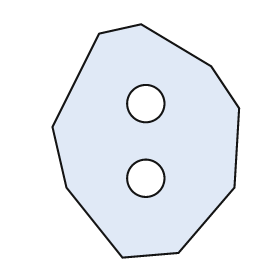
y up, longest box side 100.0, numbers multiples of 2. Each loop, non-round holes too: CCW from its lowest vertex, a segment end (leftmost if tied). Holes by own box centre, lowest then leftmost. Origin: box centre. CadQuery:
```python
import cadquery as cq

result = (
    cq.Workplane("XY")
    .moveTo(-10.0, -50.0)
    .lineTo(14.0, -48.0)
    .lineTo(38.0, -20.0)
    .lineTo(40.0, 14.0)
    .lineTo(28.0, 32.0)
    .lineTo(-2.0, 50.0)
    .lineTo(-20.0, 46.0)
    .lineTo(-40.0, 6.0)
    .lineTo(-34.0, -20.0)
    .close()
    .moveTo(0.0, -16.0)
    .circle(8.0)
    .moveTo(0.0, 16.0)
    .circle(8.0)
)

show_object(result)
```